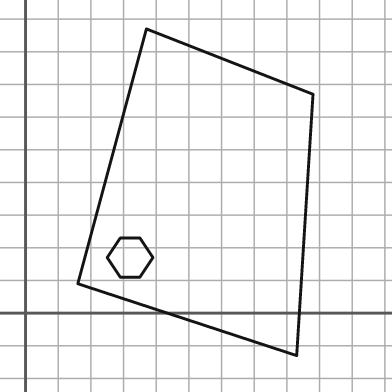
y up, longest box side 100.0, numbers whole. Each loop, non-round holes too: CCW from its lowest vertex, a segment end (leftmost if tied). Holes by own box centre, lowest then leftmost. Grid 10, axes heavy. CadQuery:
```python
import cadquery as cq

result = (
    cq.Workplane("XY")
    .moveTo(83.0, -13.0)
    .lineTo(88.0, 67.0)
    .lineTo(37.0, 87.0)
    .lineTo(16.0, 9.0)
    .close()
    .moveTo(29.0, 11.0)
    .lineTo(35.0, 11.0)
    .lineTo(39.0, 17.0)
    .lineTo(35.0, 23.0)
    .lineTo(29.0, 23.0)
    .lineTo(25.0, 17.0)
    .close()
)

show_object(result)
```